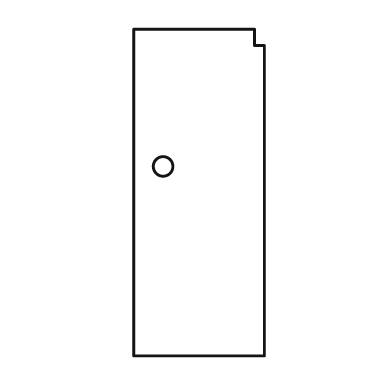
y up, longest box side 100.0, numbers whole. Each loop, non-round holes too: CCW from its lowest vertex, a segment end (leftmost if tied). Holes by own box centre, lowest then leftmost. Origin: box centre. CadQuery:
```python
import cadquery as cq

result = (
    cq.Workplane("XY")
    .moveTo(-20.0, -50.0)
    .lineTo(20.0, -50.0)
    .lineTo(20.0, 45.0)
    .lineTo(17.0, 45.0)
    .lineTo(17.0, 50.0)
    .lineTo(-20.0, 50.0)
    .close()
    .moveTo(-11.0, 8.0)
    .circle(3.0)
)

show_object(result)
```